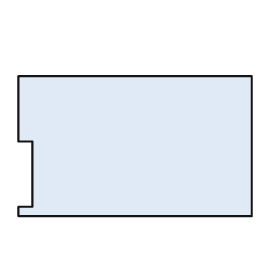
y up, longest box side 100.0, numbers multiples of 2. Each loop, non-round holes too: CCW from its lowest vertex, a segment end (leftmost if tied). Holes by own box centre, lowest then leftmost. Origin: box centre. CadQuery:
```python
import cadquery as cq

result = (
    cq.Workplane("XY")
    .moveTo(-50.0, -30.0)
    .lineTo(50.0, -30.0)
    .lineTo(50.0, 30.0)
    .lineTo(-50.0, 30.0)
    .lineTo(-50.0, 2.0)
    .lineTo(-44.0, 2.0)
    .lineTo(-44.0, -26.0)
    .lineTo(-50.0, -26.0)
    .close()
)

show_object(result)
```